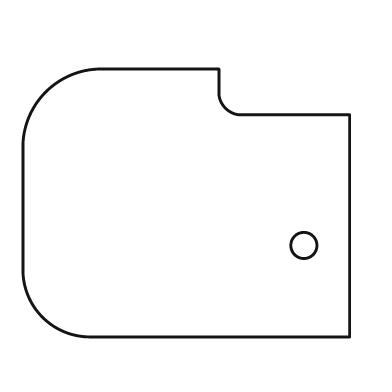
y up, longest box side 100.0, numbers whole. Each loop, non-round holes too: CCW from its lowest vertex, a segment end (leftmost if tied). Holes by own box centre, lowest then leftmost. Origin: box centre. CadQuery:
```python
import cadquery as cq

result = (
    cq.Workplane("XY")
    .moveTo(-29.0, -41.0)
    .lineTo(50.0, -41.0)
    .lineTo(50.0, 27.0)
    .lineTo(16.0, 27.0)
    .threePointArc((12.0, 29.0), (10.0, 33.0))
    .lineTo(10.0, 41.0)
    .lineTo(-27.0, 41.0)
    .threePointArc((-43.0, 34.0), (-50.0, 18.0))
    .lineTo(-50.0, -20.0)
    .threePointArc((-44.0, -35.0), (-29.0, -41.0))
    .close()
    .moveTo(36.0, -13.0)
    .circle(4.0)
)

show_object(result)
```